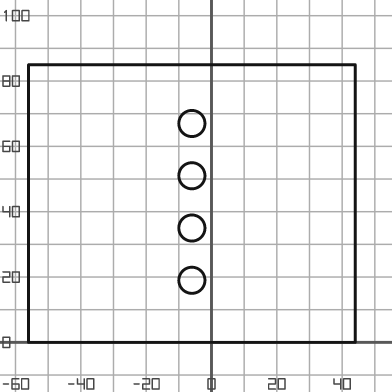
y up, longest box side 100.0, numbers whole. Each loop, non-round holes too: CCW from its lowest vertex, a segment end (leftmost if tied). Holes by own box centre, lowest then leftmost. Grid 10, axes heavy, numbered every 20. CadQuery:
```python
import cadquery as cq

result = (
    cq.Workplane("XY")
    .moveTo(-56.0, 0.0)
    .lineTo(44.0, 0.0)
    .lineTo(44.0, 85.0)
    .lineTo(-56.0, 85.0)
    .close()
    .moveTo(-6.0, 19.0)
    .circle(4.0)
    .moveTo(-6.0, 35.0)
    .circle(4.0)
    .moveTo(-6.0, 51.0)
    .circle(4.0)
    .moveTo(-6.0, 67.0)
    .circle(4.0)
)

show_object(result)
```